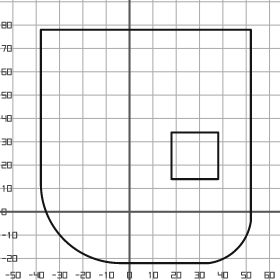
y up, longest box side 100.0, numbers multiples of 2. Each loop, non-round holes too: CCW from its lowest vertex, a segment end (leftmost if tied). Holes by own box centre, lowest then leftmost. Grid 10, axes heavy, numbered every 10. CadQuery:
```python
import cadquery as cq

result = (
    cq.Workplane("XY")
    .moveTo(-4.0, -22.0)
    .lineTo(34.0, -22.0)
    .threePointArc((46.0, -16.0), (52.0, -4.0))
    .lineTo(52.0, 78.0)
    .lineTo(-38.0, 78.0)
    .lineTo(-38.0, 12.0)
    .threePointArc((-28.0, -12.0), (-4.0, -22.0))
    .close()
    .moveTo(18.0, 14.0)
    .lineTo(38.0, 14.0)
    .lineTo(38.0, 34.0)
    .lineTo(18.0, 34.0)
    .close()
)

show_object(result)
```